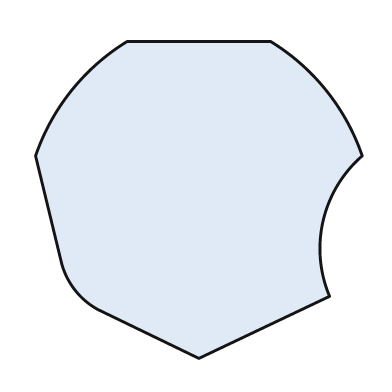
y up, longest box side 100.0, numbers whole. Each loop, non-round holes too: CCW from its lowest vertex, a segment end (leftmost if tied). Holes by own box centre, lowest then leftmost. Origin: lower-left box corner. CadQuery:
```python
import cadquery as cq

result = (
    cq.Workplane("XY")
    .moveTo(50.0, 0.0)
    .lineTo(90.0, 19.0)
    .threePointArc((88.0, 42.0), (100.0, 62.0))
    .threePointArc((89.0, 82.0), (72.0, 97.0))
    .lineTo(28.0, 97.0)
    .threePointArc((11.0, 82.0), (0.0, 62.0))
    .lineTo(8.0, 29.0)
    .threePointArc((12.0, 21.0), (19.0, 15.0))
    .close()
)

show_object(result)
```